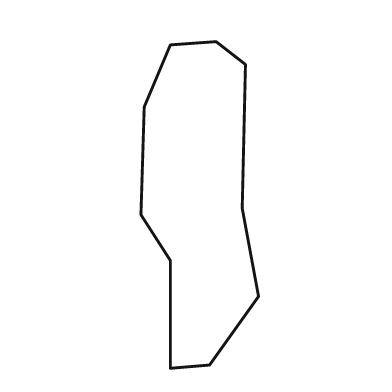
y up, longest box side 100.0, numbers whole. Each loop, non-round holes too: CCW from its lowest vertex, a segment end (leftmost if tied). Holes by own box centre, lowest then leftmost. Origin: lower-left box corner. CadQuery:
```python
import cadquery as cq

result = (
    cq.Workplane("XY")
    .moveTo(9.0, 0.0)
    .lineTo(21.0, 1.0)
    .lineTo(36.0, 22.0)
    .lineTo(31.0, 49.0)
    .lineTo(32.0, 93.0)
    .lineTo(23.0, 100.0)
    .lineTo(9.0, 99.0)
    .lineTo(1.0, 80.0)
    .lineTo(0.0, 47.0)
    .lineTo(9.0, 33.0)
    .close()
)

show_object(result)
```